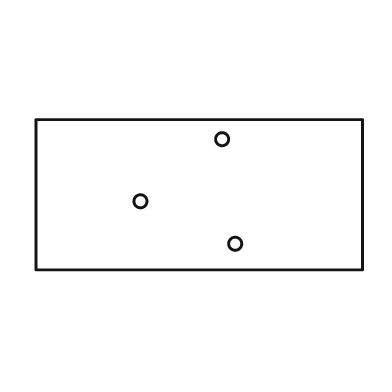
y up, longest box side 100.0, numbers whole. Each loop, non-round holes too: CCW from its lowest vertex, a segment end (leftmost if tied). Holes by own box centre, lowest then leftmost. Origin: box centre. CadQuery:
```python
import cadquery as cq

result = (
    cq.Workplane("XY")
    .moveTo(-50.0, -23.0)
    .lineTo(50.0, -23.0)
    .lineTo(50.0, 23.0)
    .lineTo(-50.0, 23.0)
    .close()
    .moveTo(11.0, -15.0)
    .circle(2.0)
    .moveTo(-18.0, -2.0)
    .circle(2.0)
    .moveTo(7.0, 17.0)
    .circle(2.0)
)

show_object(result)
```